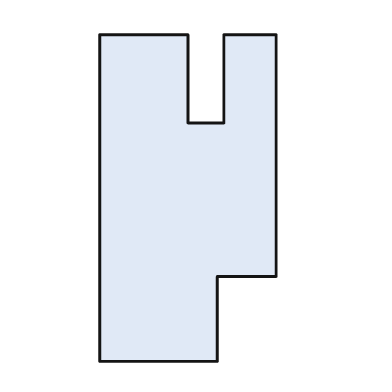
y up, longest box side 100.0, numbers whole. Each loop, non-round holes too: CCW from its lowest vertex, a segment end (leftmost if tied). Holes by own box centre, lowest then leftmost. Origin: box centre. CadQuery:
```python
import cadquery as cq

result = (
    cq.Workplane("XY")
    .moveTo(-27.0, -50.0)
    .lineTo(9.0, -50.0)
    .lineTo(9.0, -24.0)
    .lineTo(27.0, -24.0)
    .lineTo(27.0, 50.0)
    .lineTo(11.0, 50.0)
    .lineTo(11.0, 23.0)
    .lineTo(0.0, 23.0)
    .lineTo(0.0, 50.0)
    .lineTo(-27.0, 50.0)
    .close()
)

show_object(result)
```